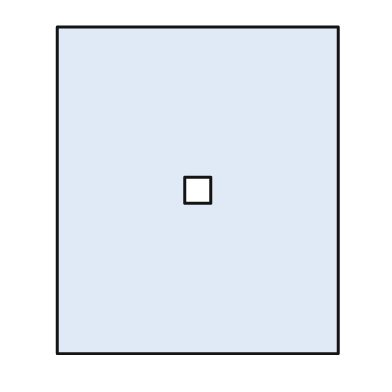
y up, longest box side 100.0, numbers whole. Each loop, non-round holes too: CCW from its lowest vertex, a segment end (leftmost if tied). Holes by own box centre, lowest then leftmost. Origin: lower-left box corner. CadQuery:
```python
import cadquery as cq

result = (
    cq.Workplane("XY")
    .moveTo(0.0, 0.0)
    .lineTo(86.0, 0.0)
    .lineTo(86.0, 100.0)
    .lineTo(0.0, 100.0)
    .close()
    .moveTo(39.0, 46.0)
    .lineTo(47.0, 46.0)
    .lineTo(47.0, 54.0)
    .lineTo(39.0, 54.0)
    .close()
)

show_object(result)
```